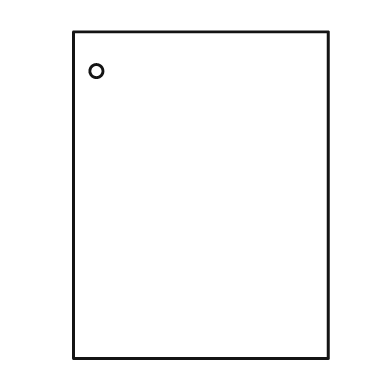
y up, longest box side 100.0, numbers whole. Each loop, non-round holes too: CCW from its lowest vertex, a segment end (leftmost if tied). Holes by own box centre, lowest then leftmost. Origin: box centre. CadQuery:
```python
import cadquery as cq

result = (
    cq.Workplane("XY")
    .moveTo(-39.0, -50.0)
    .lineTo(39.0, -50.0)
    .lineTo(39.0, 50.0)
    .lineTo(-39.0, 50.0)
    .close()
    .moveTo(-32.0, 38.0)
    .circle(2.0)
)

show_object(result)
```